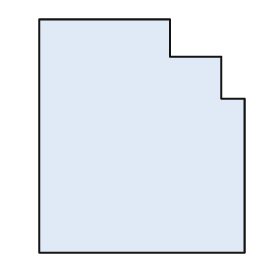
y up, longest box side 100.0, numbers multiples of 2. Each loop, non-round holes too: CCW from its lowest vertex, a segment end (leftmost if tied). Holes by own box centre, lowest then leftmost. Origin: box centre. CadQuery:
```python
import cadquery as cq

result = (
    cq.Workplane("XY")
    .moveTo(-44.0, -50.0)
    .lineTo(44.0, -50.0)
    .lineTo(44.0, 16.0)
    .lineTo(34.0, 16.0)
    .lineTo(34.0, 34.0)
    .lineTo(12.0, 34.0)
    .lineTo(12.0, 50.0)
    .lineTo(-44.0, 50.0)
    .close()
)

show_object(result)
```